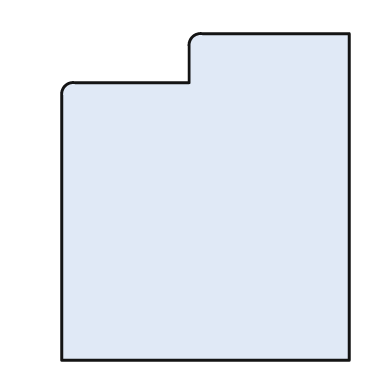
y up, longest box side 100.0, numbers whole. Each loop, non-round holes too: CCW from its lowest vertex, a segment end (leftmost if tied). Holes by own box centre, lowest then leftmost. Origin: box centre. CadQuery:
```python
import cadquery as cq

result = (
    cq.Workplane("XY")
    .moveTo(-44.0, -50.0)
    .lineTo(44.0, -50.0)
    .lineTo(44.0, 50.0)
    .lineTo(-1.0, 50.0)
    .threePointArc((-4.0, 49.0), (-5.0, 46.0))
    .lineTo(-5.0, 35.0)
    .lineTo(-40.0, 35.0)
    .threePointArc((-43.0, 34.0), (-44.0, 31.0))
    .close()
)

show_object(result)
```